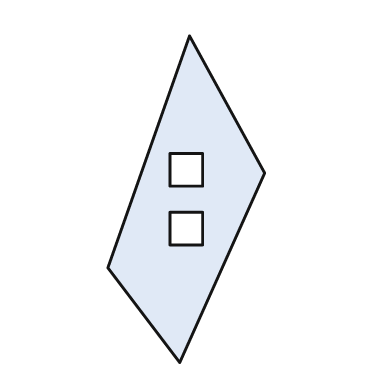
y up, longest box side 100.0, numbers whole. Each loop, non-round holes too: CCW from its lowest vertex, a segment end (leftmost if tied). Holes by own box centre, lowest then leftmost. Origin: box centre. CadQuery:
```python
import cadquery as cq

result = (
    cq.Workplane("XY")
    .moveTo(-2.0, -50.0)
    .lineTo(24.0, 8.0)
    .lineTo(1.0, 50.0)
    .lineTo(-24.0, -21.0)
    .close()
    .moveTo(-5.0, -14.0)
    .lineTo(5.0, -14.0)
    .lineTo(5.0, -4.0)
    .lineTo(-5.0, -4.0)
    .close()
    .moveTo(-5.0, 4.0)
    .lineTo(5.0, 4.0)
    .lineTo(5.0, 14.0)
    .lineTo(-5.0, 14.0)
    .close()
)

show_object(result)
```